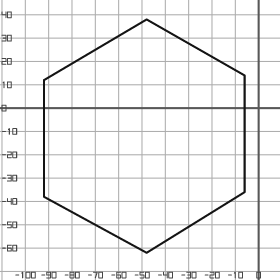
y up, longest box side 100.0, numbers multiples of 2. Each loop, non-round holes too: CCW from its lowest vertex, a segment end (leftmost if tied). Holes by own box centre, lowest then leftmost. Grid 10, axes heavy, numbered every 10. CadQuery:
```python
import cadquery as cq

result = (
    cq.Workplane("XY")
    .moveTo(-48.0, -62.0)
    .lineTo(-6.0, -36.0)
    .lineTo(-6.0, 14.0)
    .lineTo(-48.0, 38.0)
    .lineTo(-92.0, 12.0)
    .lineTo(-92.0, -38.0)
    .close()
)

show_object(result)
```